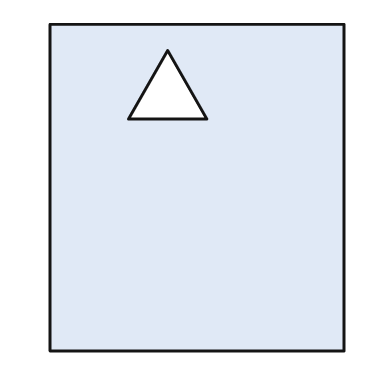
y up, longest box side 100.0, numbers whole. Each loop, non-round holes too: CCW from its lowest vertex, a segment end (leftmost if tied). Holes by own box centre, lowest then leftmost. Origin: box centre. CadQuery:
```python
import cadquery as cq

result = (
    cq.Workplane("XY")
    .moveTo(-45.0, -50.0)
    .lineTo(45.0, -50.0)
    .lineTo(45.0, 50.0)
    .lineTo(-45.0, 50.0)
    .close()
    .moveTo(-21.0, 21.0)
    .lineTo(3.0, 21.0)
    .lineTo(-9.0, 42.0)
    .close()
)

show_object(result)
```